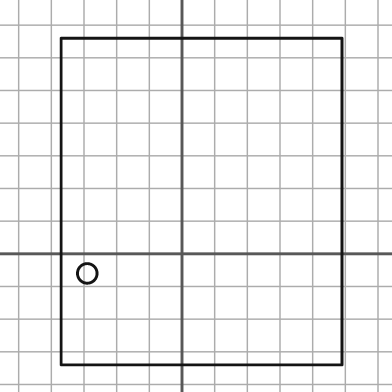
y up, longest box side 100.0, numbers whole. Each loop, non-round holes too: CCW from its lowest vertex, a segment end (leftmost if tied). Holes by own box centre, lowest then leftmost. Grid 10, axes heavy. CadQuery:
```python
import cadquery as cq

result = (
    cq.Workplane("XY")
    .moveTo(-37.0, -34.0)
    .lineTo(49.0, -34.0)
    .lineTo(49.0, 66.0)
    .lineTo(-37.0, 66.0)
    .close()
    .moveTo(-29.0, -6.0)
    .circle(3.0)
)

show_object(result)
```